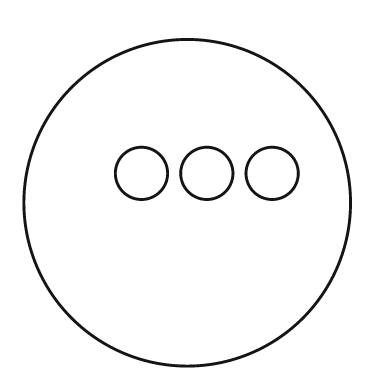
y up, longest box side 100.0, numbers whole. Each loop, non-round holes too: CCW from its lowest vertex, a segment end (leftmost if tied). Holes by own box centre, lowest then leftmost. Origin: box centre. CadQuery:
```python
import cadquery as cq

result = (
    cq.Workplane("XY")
    .moveTo(0.0, 0.0)
    .circle(50.0)
    .moveTo(-14.0, 9.0)
    .circle(8.0)
    .moveTo(6.0, 9.0)
    .circle(8.0)
    .moveTo(26.0, 9.0)
    .circle(8.0)
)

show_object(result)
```